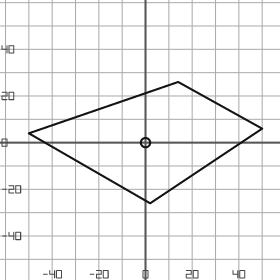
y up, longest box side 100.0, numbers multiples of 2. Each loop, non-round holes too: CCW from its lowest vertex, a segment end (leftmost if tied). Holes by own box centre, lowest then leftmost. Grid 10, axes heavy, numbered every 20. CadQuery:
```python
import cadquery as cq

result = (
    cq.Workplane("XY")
    .moveTo(2.0, -26.0)
    .lineTo(50.0, 6.0)
    .lineTo(14.0, 26.0)
    .lineTo(-50.0, 4.0)
    .close()
    .moveTo(0.0, 0.0)
    .circle(2.0)
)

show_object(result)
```